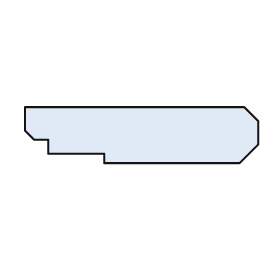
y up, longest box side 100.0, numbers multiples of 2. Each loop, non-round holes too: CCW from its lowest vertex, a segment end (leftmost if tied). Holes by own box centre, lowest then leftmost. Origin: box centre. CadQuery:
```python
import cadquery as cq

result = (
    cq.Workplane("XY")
    .moveTo(-16.0, -12.0)
    .lineTo(42.0, -12.0)
    .lineTo(50.0, -4.0)
    .lineTo(50.0, 6.0)
    .lineTo(44.0, 12.0)
    .lineTo(-50.0, 12.0)
    .lineTo(-50.0, 2.0)
    .lineTo(-46.0, -2.0)
    .lineTo(-40.0, -2.0)
    .lineTo(-40.0, -8.0)
    .lineTo(-16.0, -8.0)
    .close()
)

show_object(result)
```